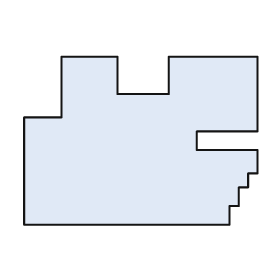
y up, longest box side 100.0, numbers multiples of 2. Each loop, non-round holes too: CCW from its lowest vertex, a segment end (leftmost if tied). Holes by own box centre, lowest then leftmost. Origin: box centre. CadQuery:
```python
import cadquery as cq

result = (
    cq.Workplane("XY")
    .moveTo(-50.0, -36.0)
    .lineTo(38.0, -36.0)
    .lineTo(38.0, -28.0)
    .lineTo(42.0, -28.0)
    .lineTo(42.0, -20.0)
    .lineTo(46.0, -20.0)
    .lineTo(46.0, -14.0)
    .lineTo(50.0, -14.0)
    .lineTo(50.0, -4.0)
    .lineTo(24.0, -4.0)
    .lineTo(24.0, 4.0)
    .lineTo(50.0, 4.0)
    .lineTo(50.0, 36.0)
    .lineTo(12.0, 36.0)
    .lineTo(12.0, 20.0)
    .lineTo(-10.0, 20.0)
    .lineTo(-10.0, 36.0)
    .lineTo(-34.0, 36.0)
    .lineTo(-34.0, 10.0)
    .lineTo(-50.0, 10.0)
    .close()
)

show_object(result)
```